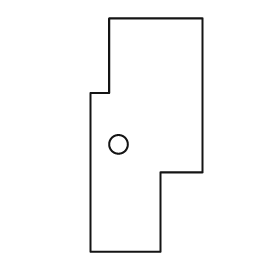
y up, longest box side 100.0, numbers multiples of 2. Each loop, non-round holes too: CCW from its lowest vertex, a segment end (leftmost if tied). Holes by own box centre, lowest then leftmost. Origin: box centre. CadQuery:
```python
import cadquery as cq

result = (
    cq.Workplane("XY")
    .moveTo(-24.0, -50.0)
    .lineTo(6.0, -50.0)
    .lineTo(6.0, -16.0)
    .lineTo(24.0, -16.0)
    .lineTo(24.0, 50.0)
    .lineTo(-16.0, 50.0)
    .lineTo(-16.0, 18.0)
    .lineTo(-24.0, 18.0)
    .close()
    .moveTo(-12.0, -4.0)
    .circle(4.0)
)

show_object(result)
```